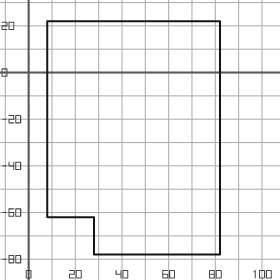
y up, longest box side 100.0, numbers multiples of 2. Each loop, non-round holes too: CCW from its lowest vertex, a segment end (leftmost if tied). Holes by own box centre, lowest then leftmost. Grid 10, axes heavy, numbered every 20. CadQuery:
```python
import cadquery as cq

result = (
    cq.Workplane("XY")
    .moveTo(28.0, -78.0)
    .lineTo(82.0, -78.0)
    .lineTo(82.0, 22.0)
    .lineTo(8.0, 22.0)
    .lineTo(8.0, -62.0)
    .lineTo(28.0, -62.0)
    .close()
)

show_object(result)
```